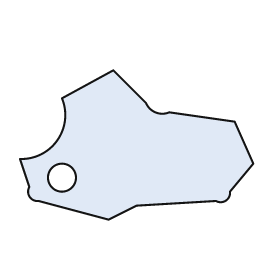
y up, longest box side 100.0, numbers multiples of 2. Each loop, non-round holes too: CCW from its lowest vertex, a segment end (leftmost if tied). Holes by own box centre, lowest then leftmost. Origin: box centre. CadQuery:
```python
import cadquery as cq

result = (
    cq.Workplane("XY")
    .moveTo(-12.0, -32.0)
    .lineTo(0.0, -26.0)
    .lineTo(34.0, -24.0)
    .threePointArc((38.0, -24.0), (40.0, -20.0))
    .lineTo(50.0, -8.0)
    .lineTo(42.0, 10.0)
    .lineTo(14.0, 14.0)
    .threePointArc((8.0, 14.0), (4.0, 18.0))
    .lineTo(-10.0, 32.0)
    .lineTo(-32.0, 20.0)
    .threePointArc((-34.0, 2.0), (-50.0, -6.0))
    .lineTo(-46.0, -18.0)
    .threePointArc((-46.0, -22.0), (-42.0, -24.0))
    .close()
    .moveTo(-32.0, -14.0)
    .circle(6.0)
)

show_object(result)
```